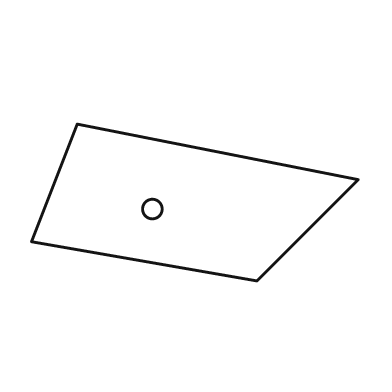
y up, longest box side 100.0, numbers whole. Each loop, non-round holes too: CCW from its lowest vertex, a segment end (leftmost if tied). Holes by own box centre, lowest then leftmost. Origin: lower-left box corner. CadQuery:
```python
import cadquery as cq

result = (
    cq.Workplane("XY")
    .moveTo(69.0, 0.0)
    .lineTo(100.0, 31.0)
    .lineTo(14.0, 48.0)
    .lineTo(0.0, 12.0)
    .close()
    .moveTo(37.0, 22.0)
    .circle(3.0)
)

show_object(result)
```